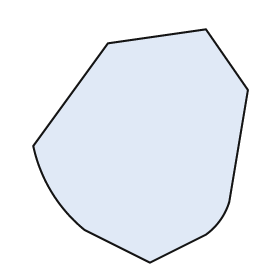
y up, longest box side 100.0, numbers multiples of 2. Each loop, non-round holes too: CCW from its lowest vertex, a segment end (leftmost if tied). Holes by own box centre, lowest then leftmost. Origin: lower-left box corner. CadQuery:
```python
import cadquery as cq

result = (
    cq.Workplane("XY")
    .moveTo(50.0, 0.0)
    .lineTo(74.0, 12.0)
    .threePointArc((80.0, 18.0), (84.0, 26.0))
    .lineTo(92.0, 74.0)
    .lineTo(74.0, 100.0)
    .lineTo(32.0, 94.0)
    .lineTo(0.0, 50.0)
    .threePointArc((8.0, 30.0), (22.0, 14.0))
    .close()
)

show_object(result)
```